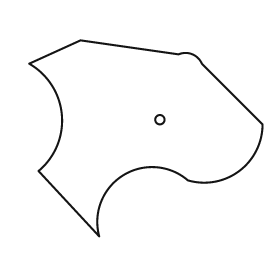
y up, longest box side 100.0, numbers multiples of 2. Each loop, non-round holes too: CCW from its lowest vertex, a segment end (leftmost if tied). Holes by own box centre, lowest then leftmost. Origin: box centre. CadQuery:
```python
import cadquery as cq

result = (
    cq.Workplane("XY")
    .moveTo(-20.0, -42.0)
    .threePointArc((-10.0, -16.0), (18.0, -18.0))
    .threePointArc((40.0, -14.0), (50.0, 6.0))
    .lineTo(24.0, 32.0)
    .threePointArc((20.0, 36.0), (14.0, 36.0))
    .lineTo(-28.0, 42.0)
    .lineTo(-50.0, 32.0)
    .threePointArc((-36.0, 10.0), (-46.0, -14.0))
    .close()
    .moveTo(6.0, 8.0)
    .circle(2.0)
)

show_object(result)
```